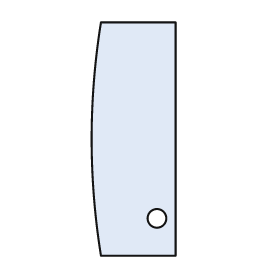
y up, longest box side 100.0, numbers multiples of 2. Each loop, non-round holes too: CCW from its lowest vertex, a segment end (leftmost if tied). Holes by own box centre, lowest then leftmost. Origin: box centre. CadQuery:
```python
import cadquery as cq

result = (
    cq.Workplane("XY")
    .moveTo(-14.0, -50.0)
    .lineTo(18.0, -50.0)
    .lineTo(18.0, 50.0)
    .lineTo(-14.0, 50.0)
    .threePointArc((-18.0, 0.0), (-14.0, -50.0))
    .close()
    .moveTo(10.0, -34.0)
    .circle(4.0)
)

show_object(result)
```